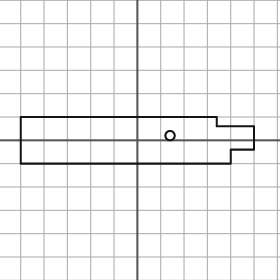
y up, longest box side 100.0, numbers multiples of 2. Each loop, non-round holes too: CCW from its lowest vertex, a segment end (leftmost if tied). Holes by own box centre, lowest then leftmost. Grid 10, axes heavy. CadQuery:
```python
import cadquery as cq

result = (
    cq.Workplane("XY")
    .moveTo(-50.0, -10.0)
    .lineTo(40.0, -10.0)
    .lineTo(40.0, -4.0)
    .lineTo(50.0, -4.0)
    .lineTo(50.0, 6.0)
    .lineTo(34.0, 6.0)
    .lineTo(34.0, 10.0)
    .lineTo(-50.0, 10.0)
    .close()
    .moveTo(14.0, 2.0)
    .circle(2.0)
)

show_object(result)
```